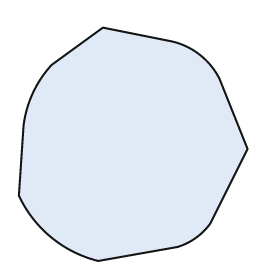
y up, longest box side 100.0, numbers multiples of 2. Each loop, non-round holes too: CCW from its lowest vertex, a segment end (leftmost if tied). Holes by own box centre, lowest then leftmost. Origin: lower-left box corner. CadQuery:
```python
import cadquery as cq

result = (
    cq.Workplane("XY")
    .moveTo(34.0, 0.0)
    .lineTo(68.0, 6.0)
    .threePointArc((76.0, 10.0), (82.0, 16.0))
    .lineTo(98.0, 48.0)
    .lineTo(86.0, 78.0)
    .threePointArc((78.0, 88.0), (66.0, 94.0))
    .lineTo(36.0, 100.0)
    .lineTo(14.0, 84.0)
    .threePointArc((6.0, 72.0), (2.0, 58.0))
    .lineTo(0.0, 28.0)
    .threePointArc((14.0, 10.0), (34.0, 0.0))
    .close()
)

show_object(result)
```